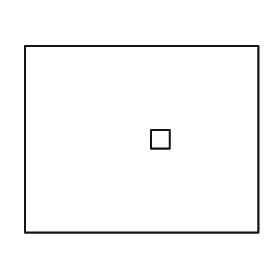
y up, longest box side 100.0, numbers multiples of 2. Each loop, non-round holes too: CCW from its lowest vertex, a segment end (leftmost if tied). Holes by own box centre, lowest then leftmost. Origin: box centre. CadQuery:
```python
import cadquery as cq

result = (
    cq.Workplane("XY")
    .moveTo(-50.0, -40.0)
    .lineTo(50.0, -40.0)
    .lineTo(50.0, 40.0)
    .lineTo(-50.0, 40.0)
    .close()
    .moveTo(4.0, -4.0)
    .lineTo(12.0, -4.0)
    .lineTo(12.0, 4.0)
    .lineTo(4.0, 4.0)
    .close()
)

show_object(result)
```